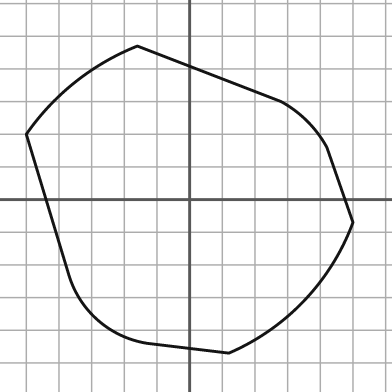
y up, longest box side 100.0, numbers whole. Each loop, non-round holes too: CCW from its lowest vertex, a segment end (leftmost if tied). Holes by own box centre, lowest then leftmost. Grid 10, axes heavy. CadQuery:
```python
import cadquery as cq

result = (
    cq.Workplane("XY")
    .moveTo(12.0, -47.0)
    .threePointArc((35.0, -31.0), (50.0, -7.0))
    .lineTo(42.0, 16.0)
    .threePointArc((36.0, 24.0), (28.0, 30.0))
    .lineTo(-16.0, 47.0)
    .threePointArc((-35.0, 36.0), (-50.0, 20.0))
    .lineTo(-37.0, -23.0)
    .threePointArc((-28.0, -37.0), (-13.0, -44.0))
    .close()
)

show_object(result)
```